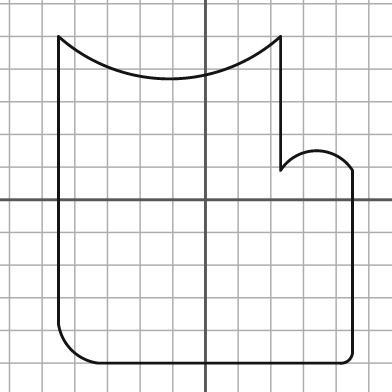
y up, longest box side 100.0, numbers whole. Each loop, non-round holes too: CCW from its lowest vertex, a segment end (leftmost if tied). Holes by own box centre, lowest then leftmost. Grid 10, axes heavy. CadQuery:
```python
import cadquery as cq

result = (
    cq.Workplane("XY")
    .moveTo(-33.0, -50.0)
    .lineTo(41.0, -50.0)
    .threePointArc((44.0, -49.0), (45.0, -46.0))
    .lineTo(45.0, 9.0)
    .threePointArc((34.0, 15.0), (23.0, 9.0))
    .lineTo(23.0, 50.0)
    .threePointArc((-11.0, 37.0), (-45.0, 50.0))
    .lineTo(-45.0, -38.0)
    .threePointArc((-41.0, -46.0), (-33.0, -50.0))
    .close()
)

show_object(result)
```